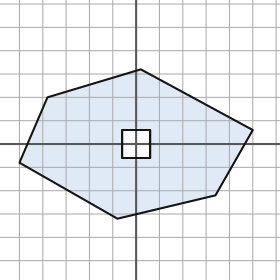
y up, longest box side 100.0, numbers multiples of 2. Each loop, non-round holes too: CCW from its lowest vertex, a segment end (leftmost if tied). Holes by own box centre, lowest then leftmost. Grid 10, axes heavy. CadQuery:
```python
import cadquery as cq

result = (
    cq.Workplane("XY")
    .moveTo(-8.0, -32.0)
    .lineTo(34.0, -22.0)
    .lineTo(50.0, 6.0)
    .lineTo(2.0, 32.0)
    .lineTo(-38.0, 20.0)
    .lineTo(-50.0, -8.0)
    .close()
    .moveTo(-6.0, -6.0)
    .lineTo(6.0, -6.0)
    .lineTo(6.0, 6.0)
    .lineTo(-6.0, 6.0)
    .close()
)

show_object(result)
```